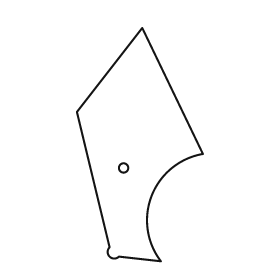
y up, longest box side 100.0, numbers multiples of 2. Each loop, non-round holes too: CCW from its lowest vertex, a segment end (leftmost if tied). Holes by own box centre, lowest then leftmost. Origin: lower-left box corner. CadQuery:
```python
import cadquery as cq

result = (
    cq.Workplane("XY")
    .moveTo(36.0, 0.0)
    .threePointArc((32.0, 28.0), (54.0, 46.0))
    .lineTo(28.0, 100.0)
    .lineTo(0.0, 64.0)
    .lineTo(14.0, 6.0)
    .threePointArc((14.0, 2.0), (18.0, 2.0))
    .close()
    .moveTo(20.0, 40.0)
    .circle(2.0)
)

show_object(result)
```